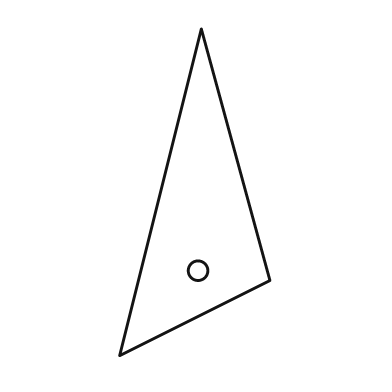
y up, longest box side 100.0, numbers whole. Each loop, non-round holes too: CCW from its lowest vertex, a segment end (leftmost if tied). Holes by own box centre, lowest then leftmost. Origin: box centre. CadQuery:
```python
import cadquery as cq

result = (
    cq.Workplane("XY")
    .moveTo(-23.0, -50.0)
    .lineTo(23.0, -27.0)
    .lineTo(2.0, 50.0)
    .close()
    .moveTo(1.0, -24.0)
    .circle(3.0)
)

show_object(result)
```